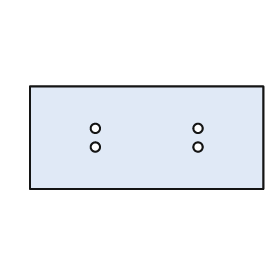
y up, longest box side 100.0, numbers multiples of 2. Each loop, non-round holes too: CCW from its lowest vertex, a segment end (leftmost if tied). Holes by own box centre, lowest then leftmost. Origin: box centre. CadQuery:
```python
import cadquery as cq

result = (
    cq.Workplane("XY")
    .moveTo(-50.0, -22.0)
    .lineTo(50.0, -22.0)
    .lineTo(50.0, 22.0)
    .lineTo(-50.0, 22.0)
    .close()
    .moveTo(-22.0, -4.0)
    .circle(2.0)
    .moveTo(22.0, -4.0)
    .circle(2.0)
    .moveTo(-22.0, 4.0)
    .circle(2.0)
    .moveTo(22.0, 4.0)
    .circle(2.0)
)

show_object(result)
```